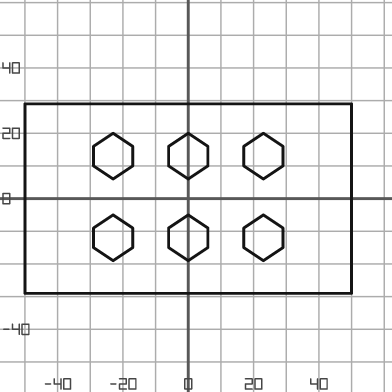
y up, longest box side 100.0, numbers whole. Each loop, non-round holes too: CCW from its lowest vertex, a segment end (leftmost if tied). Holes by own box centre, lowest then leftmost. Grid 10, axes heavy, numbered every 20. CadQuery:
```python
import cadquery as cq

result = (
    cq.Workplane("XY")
    .moveTo(-50.0, -29.0)
    .lineTo(50.0, -29.0)
    .lineTo(50.0, 29.0)
    .lineTo(-50.0, 29.0)
    .close()
    .moveTo(-23.0, -19.0)
    .lineTo(-17.0, -15.0)
    .lineTo(-17.0, -9.0)
    .lineTo(-23.0, -5.0)
    .lineTo(-29.0, -9.0)
    .lineTo(-29.0, -15.0)
    .close()
    .moveTo(0.0, -19.0)
    .lineTo(6.0, -15.0)
    .lineTo(6.0, -9.0)
    .lineTo(0.0, -5.0)
    .lineTo(-6.0, -9.0)
    .lineTo(-6.0, -15.0)
    .close()
    .moveTo(23.0, -19.0)
    .lineTo(29.0, -15.0)
    .lineTo(29.0, -9.0)
    .lineTo(23.0, -5.0)
    .lineTo(17.0, -9.0)
    .lineTo(17.0, -15.0)
    .close()
    .moveTo(-23.0, 6.0)
    .lineTo(-17.0, 10.0)
    .lineTo(-17.0, 16.0)
    .lineTo(-23.0, 20.0)
    .lineTo(-29.0, 16.0)
    .lineTo(-29.0, 10.0)
    .close()
    .moveTo(0.0, 6.0)
    .lineTo(6.0, 10.0)
    .lineTo(6.0, 16.0)
    .lineTo(0.0, 20.0)
    .lineTo(-6.0, 16.0)
    .lineTo(-6.0, 10.0)
    .close()
    .moveTo(23.0, 6.0)
    .lineTo(29.0, 10.0)
    .lineTo(29.0, 16.0)
    .lineTo(23.0, 20.0)
    .lineTo(17.0, 16.0)
    .lineTo(17.0, 10.0)
    .close()
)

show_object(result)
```